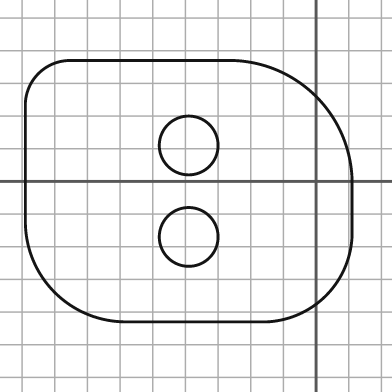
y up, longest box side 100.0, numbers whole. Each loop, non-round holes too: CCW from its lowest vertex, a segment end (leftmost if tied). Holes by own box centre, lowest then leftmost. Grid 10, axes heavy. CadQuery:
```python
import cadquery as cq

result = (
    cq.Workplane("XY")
    .moveTo(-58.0, -43.0)
    .lineTo(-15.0, -43.0)
    .threePointArc((3.0, -35.0), (11.0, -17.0))
    .lineTo(11.0, 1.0)
    .threePointArc((0.0, 26.0), (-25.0, 37.0))
    .lineTo(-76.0, 37.0)
    .threePointArc((-85.0, 33.0), (-89.0, 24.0))
    .lineTo(-89.0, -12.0)
    .threePointArc((-80.0, -34.0), (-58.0, -43.0))
    .close()
    .moveTo(-39.0, -17.0)
    .circle(9.0)
    .moveTo(-39.0, 11.0)
    .circle(9.0)
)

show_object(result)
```